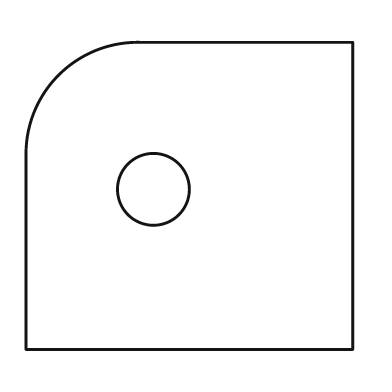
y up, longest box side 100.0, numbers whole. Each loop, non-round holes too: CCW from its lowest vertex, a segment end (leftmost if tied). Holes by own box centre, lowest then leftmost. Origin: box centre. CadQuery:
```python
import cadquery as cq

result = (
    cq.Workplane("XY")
    .moveTo(-50.0, -47.0)
    .lineTo(50.0, -47.0)
    .lineTo(50.0, 47.0)
    .lineTo(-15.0, 47.0)
    .threePointArc((-40.0, 37.0), (-50.0, 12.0))
    .close()
    .moveTo(-11.0, 2.0)
    .circle(11.0)
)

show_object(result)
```